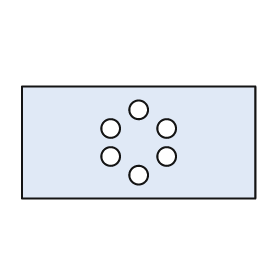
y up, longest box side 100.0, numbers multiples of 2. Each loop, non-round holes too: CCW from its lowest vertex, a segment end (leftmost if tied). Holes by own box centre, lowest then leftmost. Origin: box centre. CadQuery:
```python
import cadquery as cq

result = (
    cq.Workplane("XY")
    .moveTo(-50.0, -24.0)
    .lineTo(50.0, -24.0)
    .lineTo(50.0, 24.0)
    .lineTo(-50.0, 24.0)
    .close()
    .moveTo(0.0, -14.0)
    .circle(4.0)
    .moveTo(-12.0, -6.0)
    .circle(4.0)
    .moveTo(12.0, -6.0)
    .circle(4.0)
    .moveTo(-12.0, 6.0)
    .circle(4.0)
    .moveTo(12.0, 6.0)
    .circle(4.0)
    .moveTo(0.0, 14.0)
    .circle(4.0)
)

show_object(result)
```